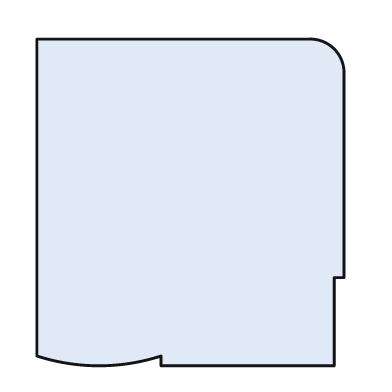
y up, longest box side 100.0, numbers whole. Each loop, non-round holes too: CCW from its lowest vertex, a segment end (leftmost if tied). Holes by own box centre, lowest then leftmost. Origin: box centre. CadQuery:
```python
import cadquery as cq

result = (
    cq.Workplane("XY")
    .moveTo(-9.0, -50.0)
    .lineTo(44.0, -50.0)
    .lineTo(44.0, -23.0)
    .lineTo(47.0, -23.0)
    .lineTo(47.0, 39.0)
    .threePointArc((44.0, 47.0), (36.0, 50.0))
    .lineTo(-47.0, 50.0)
    .lineTo(-47.0, -47.0)
    .threePointArc((-28.0, -50.0), (-9.0, -47.0))
    .close()
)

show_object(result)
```